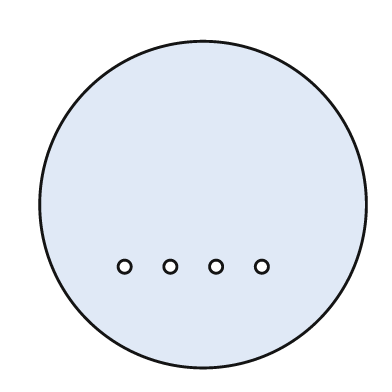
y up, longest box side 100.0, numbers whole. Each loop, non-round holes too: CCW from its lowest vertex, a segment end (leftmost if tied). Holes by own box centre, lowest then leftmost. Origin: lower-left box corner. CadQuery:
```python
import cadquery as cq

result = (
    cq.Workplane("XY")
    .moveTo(50.0, 50.0)
    .circle(50.0)
    .moveTo(26.0, 31.0)
    .circle(2.0)
    .moveTo(40.0, 31.0)
    .circle(2.0)
    .moveTo(54.0, 31.0)
    .circle(2.0)
    .moveTo(68.0, 31.0)
    .circle(2.0)
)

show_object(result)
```